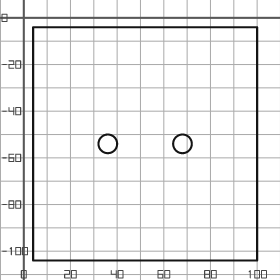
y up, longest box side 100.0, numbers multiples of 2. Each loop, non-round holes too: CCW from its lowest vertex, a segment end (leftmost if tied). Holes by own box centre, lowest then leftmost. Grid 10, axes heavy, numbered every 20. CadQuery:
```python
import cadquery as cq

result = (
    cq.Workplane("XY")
    .moveTo(4.0, -104.0)
    .lineTo(100.0, -104.0)
    .lineTo(100.0, -4.0)
    .lineTo(4.0, -4.0)
    .close()
    .moveTo(36.0, -54.0)
    .circle(4.0)
    .moveTo(68.0, -54.0)
    .circle(4.0)
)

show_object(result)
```